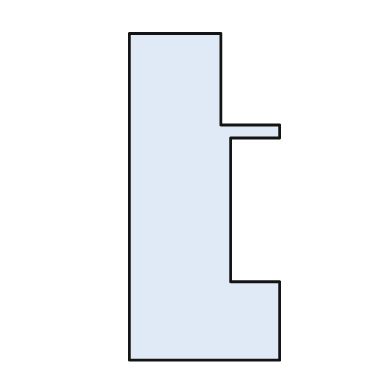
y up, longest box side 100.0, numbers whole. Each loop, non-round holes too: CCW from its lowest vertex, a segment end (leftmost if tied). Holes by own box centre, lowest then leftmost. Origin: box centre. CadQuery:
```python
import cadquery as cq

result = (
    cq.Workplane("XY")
    .moveTo(-23.0, -50.0)
    .lineTo(23.0, -50.0)
    .lineTo(23.0, -26.0)
    .lineTo(8.0, -26.0)
    .lineTo(8.0, 18.0)
    .lineTo(23.0, 18.0)
    .lineTo(23.0, 22.0)
    .lineTo(5.0, 22.0)
    .lineTo(5.0, 50.0)
    .lineTo(-23.0, 50.0)
    .close()
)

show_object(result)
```